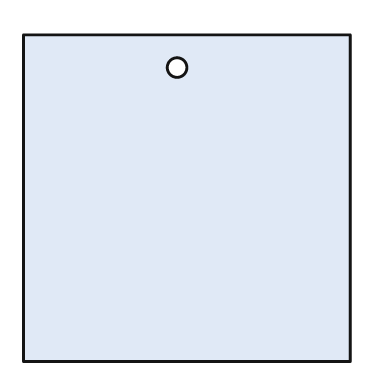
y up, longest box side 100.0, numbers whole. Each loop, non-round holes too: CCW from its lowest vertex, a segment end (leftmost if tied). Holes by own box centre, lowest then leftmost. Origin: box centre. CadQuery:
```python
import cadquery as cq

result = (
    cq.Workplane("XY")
    .moveTo(-50.0, -50.0)
    .lineTo(50.0, -50.0)
    .lineTo(50.0, 50.0)
    .lineTo(-50.0, 50.0)
    .close()
    .moveTo(-3.0, 40.0)
    .circle(3.0)
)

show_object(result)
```